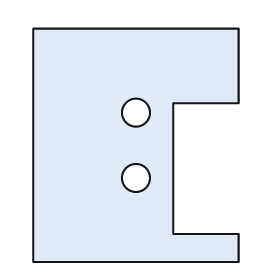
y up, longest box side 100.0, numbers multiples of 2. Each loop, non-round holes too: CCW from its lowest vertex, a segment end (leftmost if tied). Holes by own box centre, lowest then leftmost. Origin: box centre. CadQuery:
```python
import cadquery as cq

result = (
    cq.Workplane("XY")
    .moveTo(-44.0, -50.0)
    .lineTo(44.0, -50.0)
    .lineTo(44.0, -38.0)
    .lineTo(16.0, -38.0)
    .lineTo(16.0, 18.0)
    .lineTo(44.0, 18.0)
    .lineTo(44.0, 50.0)
    .lineTo(-44.0, 50.0)
    .close()
    .moveTo(0.0, -14.0)
    .circle(6.0)
    .moveTo(0.0, 14.0)
    .circle(6.0)
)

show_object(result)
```